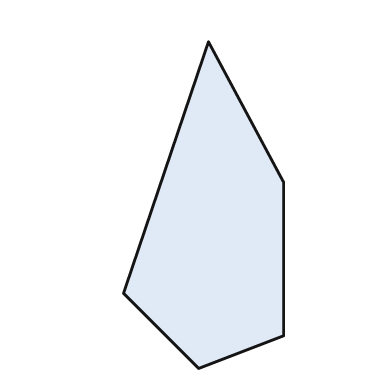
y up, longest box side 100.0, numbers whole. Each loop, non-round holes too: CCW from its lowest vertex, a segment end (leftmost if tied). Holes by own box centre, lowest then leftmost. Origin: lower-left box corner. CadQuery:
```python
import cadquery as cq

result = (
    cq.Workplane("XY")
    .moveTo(23.0, 0.0)
    .lineTo(49.0, 10.0)
    .lineTo(49.0, 57.0)
    .lineTo(26.0, 100.0)
    .lineTo(0.0, 23.0)
    .close()
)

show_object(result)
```